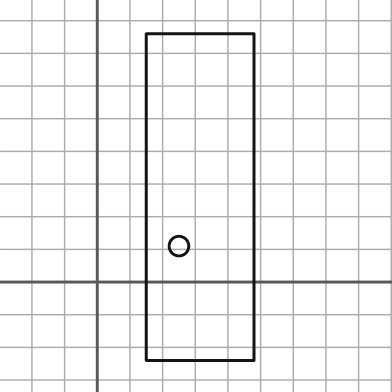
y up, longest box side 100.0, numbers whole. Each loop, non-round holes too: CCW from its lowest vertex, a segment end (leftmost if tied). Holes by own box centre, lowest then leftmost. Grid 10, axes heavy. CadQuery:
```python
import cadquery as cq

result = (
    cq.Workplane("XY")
    .moveTo(15.0, -24.0)
    .lineTo(48.0, -24.0)
    .lineTo(48.0, 76.0)
    .lineTo(15.0, 76.0)
    .close()
    .moveTo(25.0, 11.0)
    .circle(3.0)
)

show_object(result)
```